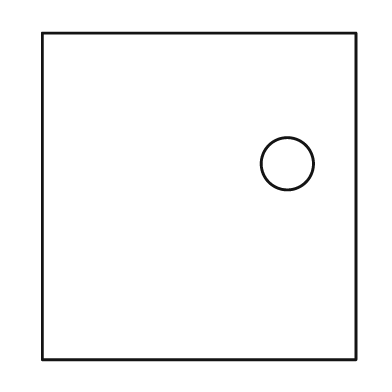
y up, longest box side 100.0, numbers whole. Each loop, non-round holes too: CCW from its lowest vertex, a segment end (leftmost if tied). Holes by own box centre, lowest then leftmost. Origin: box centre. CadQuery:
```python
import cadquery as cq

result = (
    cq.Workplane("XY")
    .moveTo(-48.0, -50.0)
    .lineTo(48.0, -50.0)
    .lineTo(48.0, 50.0)
    .lineTo(-48.0, 50.0)
    .close()
    .moveTo(27.0, 10.0)
    .circle(8.0)
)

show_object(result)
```